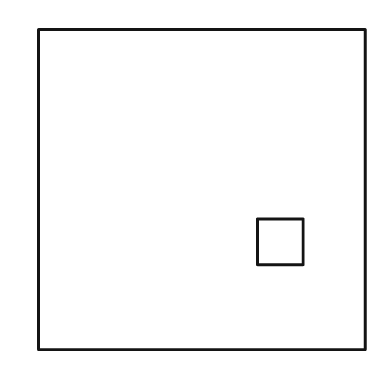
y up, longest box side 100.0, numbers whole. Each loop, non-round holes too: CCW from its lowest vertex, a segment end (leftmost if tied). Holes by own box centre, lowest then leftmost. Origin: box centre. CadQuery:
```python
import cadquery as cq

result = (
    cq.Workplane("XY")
    .moveTo(-50.0, -49.0)
    .lineTo(50.0, -49.0)
    .lineTo(50.0, 49.0)
    .lineTo(-50.0, 49.0)
    .close()
    .moveTo(17.0, -23.0)
    .lineTo(31.0, -23.0)
    .lineTo(31.0, -9.0)
    .lineTo(17.0, -9.0)
    .close()
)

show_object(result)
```